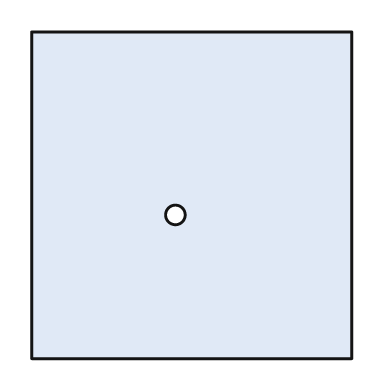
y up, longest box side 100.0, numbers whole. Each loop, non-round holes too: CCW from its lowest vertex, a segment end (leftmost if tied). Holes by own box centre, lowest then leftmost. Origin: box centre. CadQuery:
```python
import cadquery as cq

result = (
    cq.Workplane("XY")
    .moveTo(-49.0, -50.0)
    .lineTo(49.0, -50.0)
    .lineTo(49.0, 50.0)
    .lineTo(-49.0, 50.0)
    .close()
    .moveTo(-5.0, -6.0)
    .circle(3.0)
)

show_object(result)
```